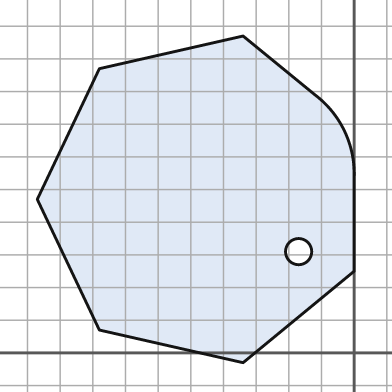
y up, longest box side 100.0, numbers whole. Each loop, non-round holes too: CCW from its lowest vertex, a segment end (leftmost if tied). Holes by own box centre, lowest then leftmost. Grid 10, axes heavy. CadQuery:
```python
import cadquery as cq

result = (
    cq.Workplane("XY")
    .moveTo(-34.0, -3.0)
    .lineTo(0.0, 25.0)
    .lineTo(0.0, 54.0)
    .threePointArc((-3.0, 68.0), (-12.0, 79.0))
    .lineTo(-34.0, 97.0)
    .lineTo(-78.0, 87.0)
    .lineTo(-97.0, 47.0)
    .lineTo(-78.0, 7.0)
    .close()
    .moveTo(-17.0, 31.0)
    .circle(4.0)
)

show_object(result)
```